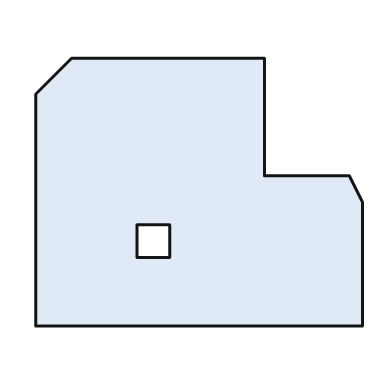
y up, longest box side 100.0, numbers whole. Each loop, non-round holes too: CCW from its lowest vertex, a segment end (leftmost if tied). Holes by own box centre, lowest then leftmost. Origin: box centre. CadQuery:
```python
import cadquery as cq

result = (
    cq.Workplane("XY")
    .moveTo(-50.0, -41.0)
    .lineTo(50.0, -41.0)
    .lineTo(50.0, -3.0)
    .lineTo(46.0, 5.0)
    .lineTo(20.0, 5.0)
    .lineTo(20.0, 41.0)
    .lineTo(-39.0, 41.0)
    .lineTo(-50.0, 30.0)
    .close()
    .moveTo(-19.0, -20.0)
    .lineTo(-9.0, -20.0)
    .lineTo(-9.0, -10.0)
    .lineTo(-19.0, -10.0)
    .close()
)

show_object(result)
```